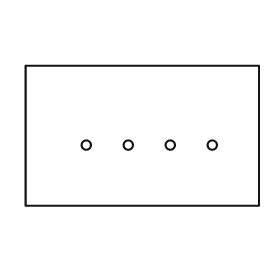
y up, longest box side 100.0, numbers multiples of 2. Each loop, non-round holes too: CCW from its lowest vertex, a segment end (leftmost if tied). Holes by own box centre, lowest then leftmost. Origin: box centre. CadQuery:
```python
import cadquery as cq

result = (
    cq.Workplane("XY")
    .moveTo(-50.0, -30.0)
    .lineTo(50.0, -30.0)
    .lineTo(50.0, 30.0)
    .lineTo(-50.0, 30.0)
    .close()
    .moveTo(-24.0, -4.0)
    .circle(2.0)
    .moveTo(-6.0, -4.0)
    .circle(2.0)
    .moveTo(12.0, -4.0)
    .circle(2.0)
    .moveTo(30.0, -4.0)
    .circle(2.0)
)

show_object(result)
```